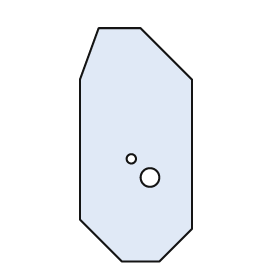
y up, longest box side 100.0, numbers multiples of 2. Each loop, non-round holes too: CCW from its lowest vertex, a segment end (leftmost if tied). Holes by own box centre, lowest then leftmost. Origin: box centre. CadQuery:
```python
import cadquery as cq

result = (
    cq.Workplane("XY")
    .moveTo(-6.0, -50.0)
    .lineTo(10.0, -50.0)
    .lineTo(24.0, -36.0)
    .lineTo(24.0, 28.0)
    .lineTo(2.0, 50.0)
    .lineTo(-16.0, 50.0)
    .lineTo(-24.0, 28.0)
    .lineTo(-24.0, -32.0)
    .close()
    .moveTo(6.0, -14.0)
    .circle(4.0)
    .moveTo(-2.0, -6.0)
    .circle(2.0)
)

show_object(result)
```